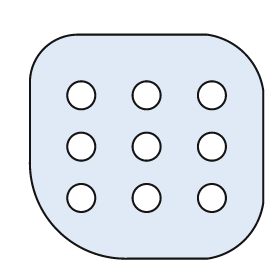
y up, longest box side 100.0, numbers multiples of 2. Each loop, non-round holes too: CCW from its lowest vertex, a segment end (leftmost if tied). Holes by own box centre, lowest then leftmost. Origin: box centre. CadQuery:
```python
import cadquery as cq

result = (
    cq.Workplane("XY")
    .moveTo(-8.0, -48.0)
    .lineTo(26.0, -48.0)
    .threePointArc((42.0, -40.0), (50.0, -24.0))
    .lineTo(50.0, 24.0)
    .threePointArc((42.0, 40.0), (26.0, 48.0))
    .lineTo(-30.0, 48.0)
    .threePointArc((-44.0, 42.0), (-50.0, 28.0))
    .lineTo(-50.0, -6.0)
    .threePointArc((-38.0, -36.0), (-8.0, -48.0))
    .close()
    .moveTo(-28.0, -22.0)
    .circle(6.0)
    .moveTo(0.0, -22.0)
    .circle(6.0)
    .moveTo(28.0, -22.0)
    .circle(6.0)
    .moveTo(-28.0, 0.0)
    .circle(6.0)
    .moveTo(0.0, 0.0)
    .circle(6.0)
    .moveTo(28.0, 0.0)
    .circle(6.0)
    .moveTo(-28.0, 22.0)
    .circle(6.0)
    .moveTo(0.0, 22.0)
    .circle(6.0)
    .moveTo(28.0, 22.0)
    .circle(6.0)
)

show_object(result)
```